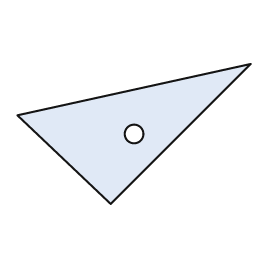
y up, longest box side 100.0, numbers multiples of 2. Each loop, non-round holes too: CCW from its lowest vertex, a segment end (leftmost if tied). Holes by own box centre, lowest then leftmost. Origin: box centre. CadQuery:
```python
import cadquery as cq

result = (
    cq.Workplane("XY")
    .moveTo(-10.0, -30.0)
    .lineTo(50.0, 30.0)
    .lineTo(-50.0, 8.0)
    .close()
    .moveTo(0.0, 0.0)
    .circle(4.0)
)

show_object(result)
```